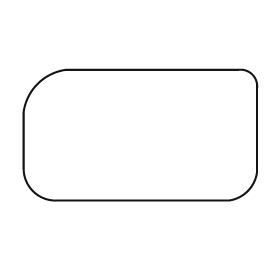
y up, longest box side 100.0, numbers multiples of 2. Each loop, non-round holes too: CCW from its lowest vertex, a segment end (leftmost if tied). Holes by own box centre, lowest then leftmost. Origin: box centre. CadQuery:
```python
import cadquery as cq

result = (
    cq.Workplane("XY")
    .moveTo(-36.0, -28.0)
    .lineTo(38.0, -28.0)
    .threePointArc((46.0, -24.0), (50.0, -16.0))
    .lineTo(50.0, 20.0)
    .threePointArc((48.0, 26.0), (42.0, 28.0))
    .lineTo(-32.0, 28.0)
    .threePointArc((-44.0, 22.0), (-50.0, 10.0))
    .lineTo(-50.0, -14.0)
    .threePointArc((-46.0, -24.0), (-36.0, -28.0))
    .close()
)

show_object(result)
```